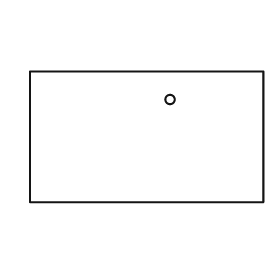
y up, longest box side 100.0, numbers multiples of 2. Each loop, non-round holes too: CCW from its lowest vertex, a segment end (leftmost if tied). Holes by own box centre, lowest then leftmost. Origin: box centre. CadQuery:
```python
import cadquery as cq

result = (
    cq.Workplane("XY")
    .moveTo(-50.0, -28.0)
    .lineTo(50.0, -28.0)
    .lineTo(50.0, 28.0)
    .lineTo(-50.0, 28.0)
    .close()
    .moveTo(10.0, 16.0)
    .circle(2.0)
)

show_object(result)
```